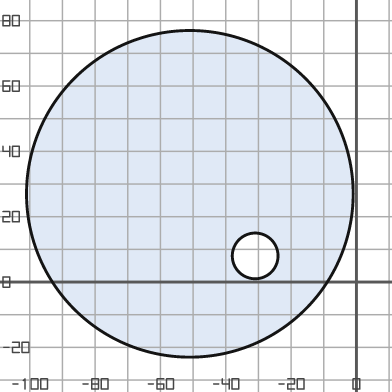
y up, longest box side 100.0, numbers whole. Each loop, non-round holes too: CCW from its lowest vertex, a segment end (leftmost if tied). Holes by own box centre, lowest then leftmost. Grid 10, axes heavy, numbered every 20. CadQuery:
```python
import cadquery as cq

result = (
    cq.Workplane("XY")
    .moveTo(-51.0, 27.0)
    .circle(50.0)
    .moveTo(-31.0, 8.0)
    .circle(7.0)
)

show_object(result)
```